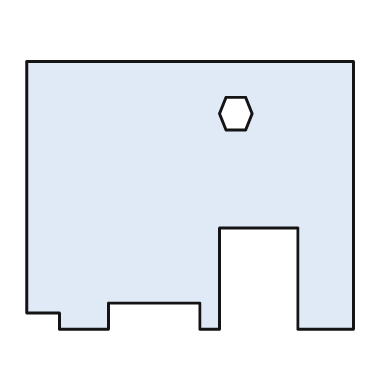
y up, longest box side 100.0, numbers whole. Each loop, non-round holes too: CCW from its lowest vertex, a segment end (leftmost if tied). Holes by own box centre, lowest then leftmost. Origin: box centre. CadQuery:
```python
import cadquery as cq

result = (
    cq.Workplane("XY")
    .moveTo(-40.0, -41.0)
    .lineTo(-25.0, -41.0)
    .lineTo(-25.0, -33.0)
    .lineTo(3.0, -33.0)
    .lineTo(3.0, -41.0)
    .lineTo(9.0, -41.0)
    .lineTo(9.0, -10.0)
    .lineTo(33.0, -10.0)
    .lineTo(33.0, -41.0)
    .lineTo(50.0, -41.0)
    .lineTo(50.0, 41.0)
    .lineTo(-50.0, 41.0)
    .lineTo(-50.0, -36.0)
    .lineTo(-40.0, -36.0)
    .close()
    .moveTo(11.0, 20.0)
    .lineTo(17.0, 20.0)
    .lineTo(19.0, 25.0)
    .lineTo(17.0, 30.0)
    .lineTo(11.0, 30.0)
    .lineTo(9.0, 25.0)
    .close()
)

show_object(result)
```